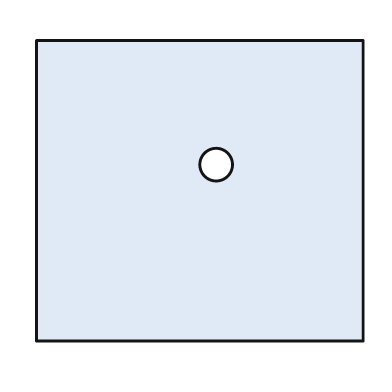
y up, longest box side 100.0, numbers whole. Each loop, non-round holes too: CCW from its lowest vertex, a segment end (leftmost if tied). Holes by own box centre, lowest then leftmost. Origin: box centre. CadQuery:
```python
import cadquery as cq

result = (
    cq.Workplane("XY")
    .moveTo(-50.0, -46.0)
    .lineTo(50.0, -46.0)
    .lineTo(50.0, 46.0)
    .lineTo(-50.0, 46.0)
    .close()
    .moveTo(5.0, 8.0)
    .circle(5.0)
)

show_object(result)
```